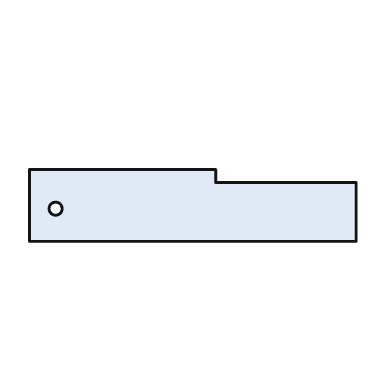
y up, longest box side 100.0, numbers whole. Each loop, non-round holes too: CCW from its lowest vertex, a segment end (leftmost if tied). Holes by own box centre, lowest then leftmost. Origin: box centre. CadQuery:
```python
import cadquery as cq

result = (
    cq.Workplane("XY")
    .moveTo(-50.0, -11.0)
    .lineTo(50.0, -11.0)
    .lineTo(50.0, 7.0)
    .lineTo(7.0, 7.0)
    .lineTo(7.0, 11.0)
    .lineTo(-50.0, 11.0)
    .close()
    .moveTo(-42.0, -1.0)
    .circle(2.0)
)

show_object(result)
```